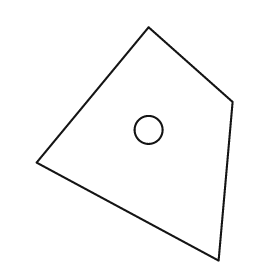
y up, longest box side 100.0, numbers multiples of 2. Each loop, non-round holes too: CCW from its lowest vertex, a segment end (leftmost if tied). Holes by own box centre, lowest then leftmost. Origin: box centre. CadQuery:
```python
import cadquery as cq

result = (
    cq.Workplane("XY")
    .moveTo(36.0, -50.0)
    .lineTo(42.0, 18.0)
    .lineTo(6.0, 50.0)
    .lineTo(-42.0, -8.0)
    .close()
    .moveTo(6.0, 6.0)
    .circle(6.0)
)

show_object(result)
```